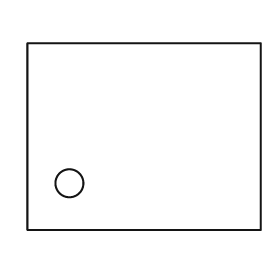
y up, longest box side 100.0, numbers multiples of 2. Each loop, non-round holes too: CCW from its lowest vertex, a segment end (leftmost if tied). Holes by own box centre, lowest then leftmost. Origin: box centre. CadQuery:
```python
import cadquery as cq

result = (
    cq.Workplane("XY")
    .moveTo(-50.0, -40.0)
    .lineTo(50.0, -40.0)
    .lineTo(50.0, 40.0)
    .lineTo(-50.0, 40.0)
    .close()
    .moveTo(-32.0, -20.0)
    .circle(6.0)
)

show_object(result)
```